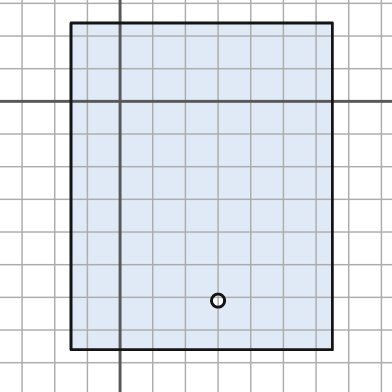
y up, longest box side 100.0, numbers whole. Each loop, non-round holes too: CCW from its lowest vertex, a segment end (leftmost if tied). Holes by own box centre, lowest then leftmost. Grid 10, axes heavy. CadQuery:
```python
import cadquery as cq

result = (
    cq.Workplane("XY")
    .moveTo(-15.0, -76.0)
    .lineTo(65.0, -76.0)
    .lineTo(65.0, 24.0)
    .lineTo(-15.0, 24.0)
    .close()
    .moveTo(30.0, -61.0)
    .circle(2.0)
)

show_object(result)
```